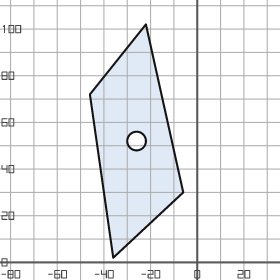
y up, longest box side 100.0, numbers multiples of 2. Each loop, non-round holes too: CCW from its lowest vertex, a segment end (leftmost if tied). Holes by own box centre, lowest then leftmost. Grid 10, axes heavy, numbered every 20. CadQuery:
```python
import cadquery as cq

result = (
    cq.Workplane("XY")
    .moveTo(-36.0, 2.0)
    .lineTo(-6.0, 30.0)
    .lineTo(-22.0, 102.0)
    .lineTo(-46.0, 72.0)
    .close()
    .moveTo(-26.0, 52.0)
    .circle(4.0)
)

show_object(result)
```